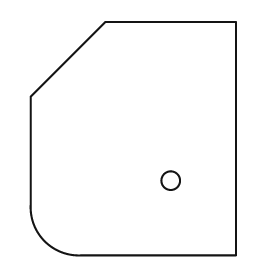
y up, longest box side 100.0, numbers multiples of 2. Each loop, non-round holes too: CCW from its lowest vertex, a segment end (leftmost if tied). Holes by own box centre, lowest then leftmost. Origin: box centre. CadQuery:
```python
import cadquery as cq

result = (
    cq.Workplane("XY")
    .moveTo(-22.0, -50.0)
    .lineTo(44.0, -50.0)
    .lineTo(44.0, 50.0)
    .lineTo(-12.0, 50.0)
    .lineTo(-44.0, 18.0)
    .lineTo(-44.0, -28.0)
    .threePointArc((-38.0, -44.0), (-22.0, -50.0))
    .close()
    .moveTo(16.0, -18.0)
    .circle(4.0)
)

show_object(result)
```